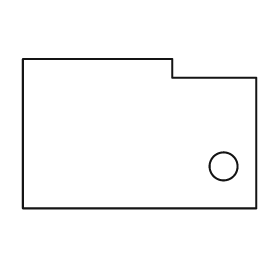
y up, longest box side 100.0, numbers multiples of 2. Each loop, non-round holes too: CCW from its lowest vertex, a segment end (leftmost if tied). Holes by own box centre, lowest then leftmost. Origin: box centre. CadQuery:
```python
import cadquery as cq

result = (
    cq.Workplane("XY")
    .moveTo(-50.0, -32.0)
    .lineTo(50.0, -32.0)
    .lineTo(50.0, 24.0)
    .lineTo(14.0, 24.0)
    .lineTo(14.0, 32.0)
    .lineTo(-50.0, 32.0)
    .close()
    .moveTo(36.0, -14.0)
    .circle(6.0)
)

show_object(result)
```